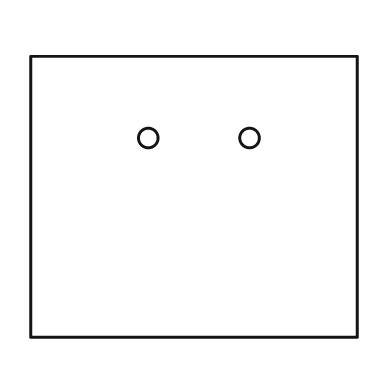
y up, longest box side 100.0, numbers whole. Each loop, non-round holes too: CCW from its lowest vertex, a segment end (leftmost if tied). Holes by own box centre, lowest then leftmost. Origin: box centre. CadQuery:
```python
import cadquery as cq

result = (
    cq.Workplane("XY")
    .moveTo(-50.0, -43.0)
    .lineTo(50.0, -43.0)
    .lineTo(50.0, 43.0)
    .lineTo(-50.0, 43.0)
    .close()
    .moveTo(-14.0, 18.0)
    .circle(3.0)
    .moveTo(17.0, 18.0)
    .circle(3.0)
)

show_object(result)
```